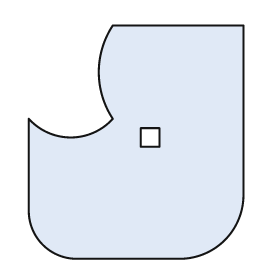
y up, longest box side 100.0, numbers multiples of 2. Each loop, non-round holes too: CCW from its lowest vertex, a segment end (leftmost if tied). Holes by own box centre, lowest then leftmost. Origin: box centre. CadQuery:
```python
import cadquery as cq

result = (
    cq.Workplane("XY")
    .moveTo(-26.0, -50.0)
    .lineTo(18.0, -50.0)
    .threePointArc((38.0, -42.0), (46.0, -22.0))
    .lineTo(46.0, 50.0)
    .lineTo(-10.0, 50.0)
    .threePointArc((-16.0, 30.0), (-10.0, 10.0))
    .threePointArc((-28.0, 2.0), (-46.0, 10.0))
    .lineTo(-46.0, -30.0)
    .threePointArc((-40.0, -44.0), (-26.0, -50.0))
    .close()
    .moveTo(2.0, -2.0)
    .lineTo(10.0, -2.0)
    .lineTo(10.0, 6.0)
    .lineTo(2.0, 6.0)
    .close()
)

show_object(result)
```